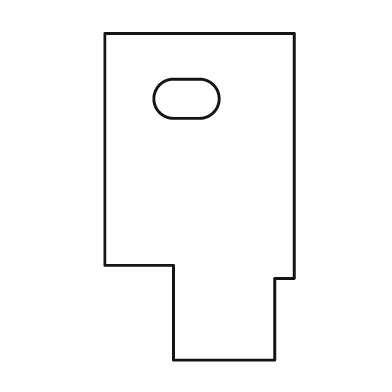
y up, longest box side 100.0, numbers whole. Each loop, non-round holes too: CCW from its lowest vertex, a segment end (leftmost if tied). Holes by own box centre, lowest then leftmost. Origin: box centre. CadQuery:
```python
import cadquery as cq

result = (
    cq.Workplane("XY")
    .moveTo(-8.0, -50.0)
    .lineTo(23.0, -50.0)
    .lineTo(23.0, -25.0)
    .lineTo(29.0, -25.0)
    .lineTo(29.0, 50.0)
    .lineTo(-29.0, 50.0)
    .lineTo(-29.0, -21.0)
    .lineTo(-8.0, -21.0)
    .close()
    .moveTo(-8.0, 24.0)
    .lineTo(0.0, 24.0)
    .threePointArc((6.0, 30.0), (0.0, 36.0))
    .lineTo(-8.0, 36.0)
    .threePointArc((-14.0, 30.0), (-8.0, 24.0))
    .close()
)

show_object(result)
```